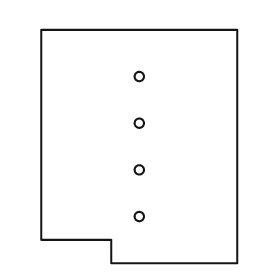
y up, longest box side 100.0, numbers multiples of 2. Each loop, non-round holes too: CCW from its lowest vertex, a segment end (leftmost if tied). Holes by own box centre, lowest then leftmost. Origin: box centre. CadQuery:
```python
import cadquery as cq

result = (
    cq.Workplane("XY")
    .moveTo(-12.0, -50.0)
    .lineTo(42.0, -50.0)
    .lineTo(42.0, 50.0)
    .lineTo(-42.0, 50.0)
    .lineTo(-42.0, -40.0)
    .lineTo(-12.0, -40.0)
    .close()
    .moveTo(0.0, -30.0)
    .circle(2.0)
    .moveTo(0.0, -10.0)
    .circle(2.0)
    .moveTo(0.0, 10.0)
    .circle(2.0)
    .moveTo(0.0, 30.0)
    .circle(2.0)
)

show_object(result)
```